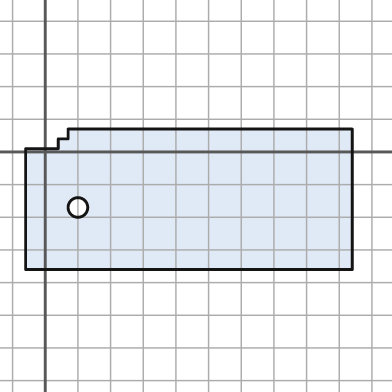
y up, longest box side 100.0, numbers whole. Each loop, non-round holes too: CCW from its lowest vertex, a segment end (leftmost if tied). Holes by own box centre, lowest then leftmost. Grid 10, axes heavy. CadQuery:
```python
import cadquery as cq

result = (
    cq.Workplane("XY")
    .moveTo(-6.0, -36.0)
    .lineTo(94.0, -36.0)
    .lineTo(94.0, 7.0)
    .lineTo(7.0, 7.0)
    .lineTo(7.0, 4.0)
    .lineTo(4.0, 4.0)
    .lineTo(4.0, 1.0)
    .lineTo(-6.0, 1.0)
    .close()
    .moveTo(10.0, -17.0)
    .circle(3.0)
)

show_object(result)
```